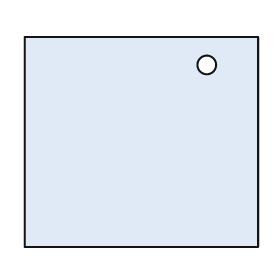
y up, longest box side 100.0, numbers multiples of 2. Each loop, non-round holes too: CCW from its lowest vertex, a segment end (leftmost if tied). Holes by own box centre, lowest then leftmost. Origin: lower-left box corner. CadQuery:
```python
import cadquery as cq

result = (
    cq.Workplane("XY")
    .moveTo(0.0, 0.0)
    .lineTo(100.0, 0.0)
    .lineTo(100.0, 90.0)
    .lineTo(0.0, 90.0)
    .close()
    .moveTo(78.0, 78.0)
    .circle(4.0)
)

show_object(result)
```